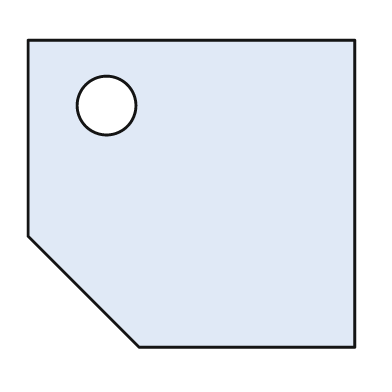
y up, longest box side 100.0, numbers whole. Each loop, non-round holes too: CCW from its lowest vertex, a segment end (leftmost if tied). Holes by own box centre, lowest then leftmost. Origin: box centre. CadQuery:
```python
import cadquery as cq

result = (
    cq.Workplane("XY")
    .moveTo(-16.0, -47.0)
    .lineTo(50.0, -47.0)
    .lineTo(50.0, 47.0)
    .lineTo(-50.0, 47.0)
    .lineTo(-50.0, -13.0)
    .close()
    .moveTo(-26.0, 27.0)
    .circle(9.0)
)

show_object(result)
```